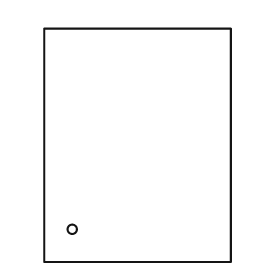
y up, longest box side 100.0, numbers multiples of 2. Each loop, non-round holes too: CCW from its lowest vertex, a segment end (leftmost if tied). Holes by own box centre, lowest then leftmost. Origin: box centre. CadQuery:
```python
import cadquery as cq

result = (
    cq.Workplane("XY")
    .moveTo(-40.0, -50.0)
    .lineTo(40.0, -50.0)
    .lineTo(40.0, 50.0)
    .lineTo(-40.0, 50.0)
    .close()
    .moveTo(-28.0, -36.0)
    .circle(2.0)
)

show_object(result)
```